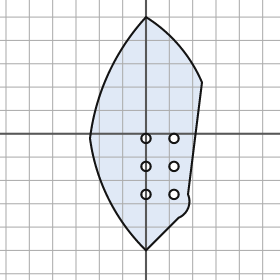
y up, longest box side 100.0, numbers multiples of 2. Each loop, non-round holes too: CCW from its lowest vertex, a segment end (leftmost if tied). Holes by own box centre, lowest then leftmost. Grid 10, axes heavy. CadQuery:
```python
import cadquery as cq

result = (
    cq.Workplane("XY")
    .moveTo(0.0, -50.0)
    .lineTo(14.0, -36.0)
    .threePointArc((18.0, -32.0), (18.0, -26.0))
    .lineTo(24.0, 22.0)
    .threePointArc((14.0, 38.0), (0.0, 50.0))
    .threePointArc((-16.0, 26.0), (-24.0, -2.0))
    .threePointArc((-16.0, -28.0), (0.0, -50.0))
    .close()
    .moveTo(0.0, -26.0)
    .circle(2.0)
    .moveTo(12.0, -26.0)
    .circle(2.0)
    .moveTo(0.0, -14.0)
    .circle(2.0)
    .moveTo(12.0, -14.0)
    .circle(2.0)
    .moveTo(0.0, -2.0)
    .circle(2.0)
    .moveTo(12.0, -2.0)
    .circle(2.0)
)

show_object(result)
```